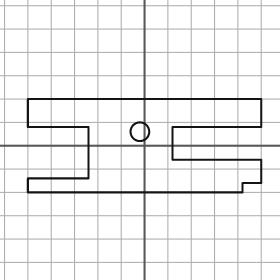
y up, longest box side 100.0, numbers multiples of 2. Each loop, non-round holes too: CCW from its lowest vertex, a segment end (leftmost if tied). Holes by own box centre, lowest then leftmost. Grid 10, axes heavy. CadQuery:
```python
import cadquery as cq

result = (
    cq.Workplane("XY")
    .moveTo(-50.0, -20.0)
    .lineTo(42.0, -20.0)
    .lineTo(42.0, -16.0)
    .lineTo(50.0, -16.0)
    .lineTo(50.0, -6.0)
    .lineTo(12.0, -6.0)
    .lineTo(12.0, 8.0)
    .lineTo(50.0, 8.0)
    .lineTo(50.0, 20.0)
    .lineTo(-50.0, 20.0)
    .lineTo(-50.0, 8.0)
    .lineTo(-24.0, 8.0)
    .lineTo(-24.0, -14.0)
    .lineTo(-50.0, -14.0)
    .close()
    .moveTo(-2.0, 6.0)
    .circle(4.0)
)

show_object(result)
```